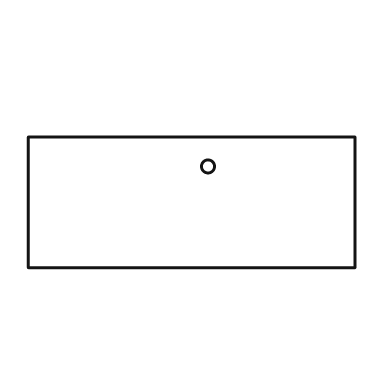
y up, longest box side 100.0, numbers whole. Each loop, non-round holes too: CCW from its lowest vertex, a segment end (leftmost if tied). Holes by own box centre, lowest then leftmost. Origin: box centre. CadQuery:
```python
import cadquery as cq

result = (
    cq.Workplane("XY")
    .moveTo(-50.0, -20.0)
    .lineTo(50.0, -20.0)
    .lineTo(50.0, 20.0)
    .lineTo(-50.0, 20.0)
    .close()
    .moveTo(5.0, 11.0)
    .circle(2.0)
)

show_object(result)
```